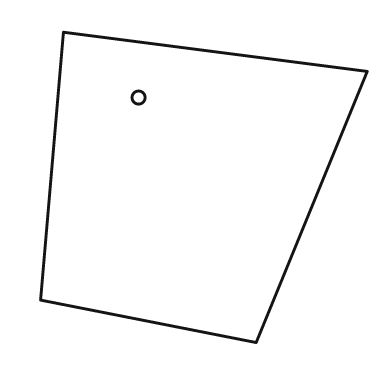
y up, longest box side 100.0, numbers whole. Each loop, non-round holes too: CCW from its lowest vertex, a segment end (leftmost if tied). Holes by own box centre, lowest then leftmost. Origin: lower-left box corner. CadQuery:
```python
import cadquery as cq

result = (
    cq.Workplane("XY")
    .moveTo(66.0, 0.0)
    .lineTo(100.0, 83.0)
    .lineTo(7.0, 95.0)
    .lineTo(0.0, 13.0)
    .close()
    .moveTo(30.0, 75.0)
    .circle(2.0)
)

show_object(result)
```